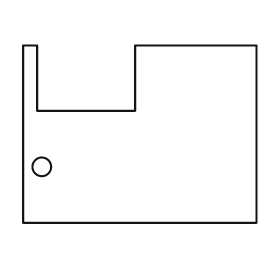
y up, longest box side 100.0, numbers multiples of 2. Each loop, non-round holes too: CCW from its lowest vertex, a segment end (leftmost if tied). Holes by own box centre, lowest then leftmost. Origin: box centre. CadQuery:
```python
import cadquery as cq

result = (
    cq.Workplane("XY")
    .moveTo(-50.0, -38.0)
    .lineTo(50.0, -38.0)
    .lineTo(50.0, 38.0)
    .lineTo(-2.0, 38.0)
    .lineTo(-2.0, 10.0)
    .lineTo(-44.0, 10.0)
    .lineTo(-44.0, 38.0)
    .lineTo(-50.0, 38.0)
    .close()
    .moveTo(-42.0, -14.0)
    .circle(4.0)
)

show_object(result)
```